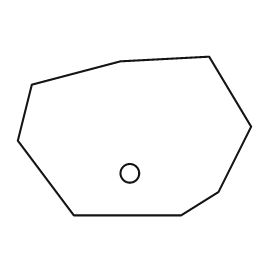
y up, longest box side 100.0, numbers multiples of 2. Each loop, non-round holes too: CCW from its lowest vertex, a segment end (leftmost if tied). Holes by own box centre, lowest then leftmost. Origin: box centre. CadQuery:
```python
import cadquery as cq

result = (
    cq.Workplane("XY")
    .moveTo(-26.0, -34.0)
    .lineTo(20.0, -34.0)
    .lineTo(36.0, -24.0)
    .lineTo(50.0, 4.0)
    .lineTo(32.0, 34.0)
    .lineTo(-6.0, 32.0)
    .lineTo(-44.0, 22.0)
    .lineTo(-50.0, -2.0)
    .close()
    .moveTo(-2.0, -16.0)
    .circle(4.0)
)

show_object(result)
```